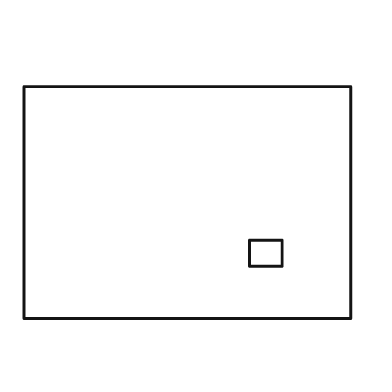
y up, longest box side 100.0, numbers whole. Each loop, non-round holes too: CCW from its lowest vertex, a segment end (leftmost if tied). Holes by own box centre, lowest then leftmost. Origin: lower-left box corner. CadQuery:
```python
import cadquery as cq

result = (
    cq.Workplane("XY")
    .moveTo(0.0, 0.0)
    .lineTo(100.0, 0.0)
    .lineTo(100.0, 71.0)
    .lineTo(0.0, 71.0)
    .close()
    .moveTo(69.0, 16.0)
    .lineTo(79.0, 16.0)
    .lineTo(79.0, 24.0)
    .lineTo(69.0, 24.0)
    .close()
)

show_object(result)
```